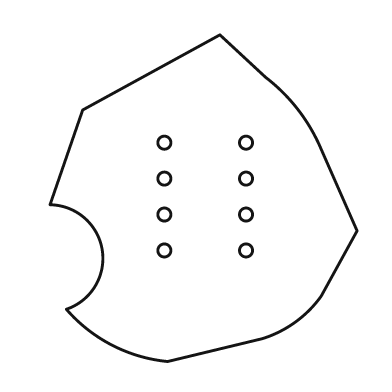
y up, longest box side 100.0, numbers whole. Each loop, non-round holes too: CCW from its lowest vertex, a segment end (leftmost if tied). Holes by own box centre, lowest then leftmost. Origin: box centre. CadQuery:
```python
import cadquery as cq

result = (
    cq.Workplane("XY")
    .moveTo(-11.0, -50.0)
    .lineTo(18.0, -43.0)
    .threePointArc((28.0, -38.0), (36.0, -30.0))
    .lineTo(47.0, -10.0)
    .lineTo(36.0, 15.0)
    .threePointArc((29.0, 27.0), (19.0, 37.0))
    .lineTo(5.0, 50.0)
    .lineTo(-37.0, 27.0)
    .lineTo(-47.0, -2.0)
    .threePointArc((-31.0, -16.0), (-42.0, -34.0))
    .threePointArc((-28.0, -45.0), (-11.0, -50.0))
    .close()
    .moveTo(-12.0, -16.0)
    .circle(2.0)
    .moveTo(13.0, -16.0)
    .circle(2.0)
    .moveTo(-12.0, -5.0)
    .circle(2.0)
    .moveTo(13.0, -5.0)
    .circle(2.0)
    .moveTo(-12.0, 6.0)
    .circle(2.0)
    .moveTo(13.0, 6.0)
    .circle(2.0)
    .moveTo(-12.0, 17.0)
    .circle(2.0)
    .moveTo(13.0, 17.0)
    .circle(2.0)
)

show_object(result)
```